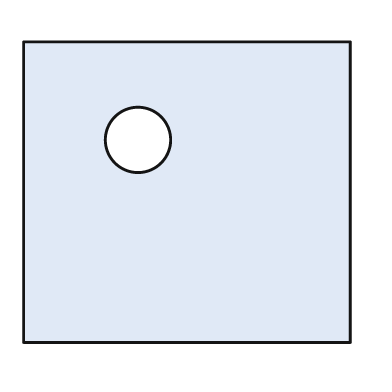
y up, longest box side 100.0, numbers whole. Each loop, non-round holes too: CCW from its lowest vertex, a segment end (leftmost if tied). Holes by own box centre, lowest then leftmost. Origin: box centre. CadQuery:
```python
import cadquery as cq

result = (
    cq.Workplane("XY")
    .moveTo(-50.0, -46.0)
    .lineTo(50.0, -46.0)
    .lineTo(50.0, 46.0)
    .lineTo(-50.0, 46.0)
    .close()
    .moveTo(-15.0, 16.0)
    .circle(10.0)
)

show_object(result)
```